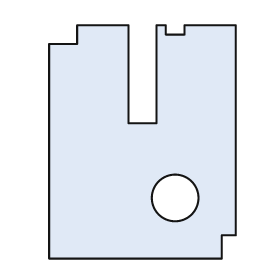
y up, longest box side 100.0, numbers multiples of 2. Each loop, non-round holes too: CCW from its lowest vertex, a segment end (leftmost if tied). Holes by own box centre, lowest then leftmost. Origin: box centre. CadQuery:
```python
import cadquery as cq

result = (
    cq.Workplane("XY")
    .moveTo(-40.0, -50.0)
    .lineTo(34.0, -50.0)
    .lineTo(34.0, -40.0)
    .lineTo(40.0, -40.0)
    .lineTo(40.0, 50.0)
    .lineTo(18.0, 50.0)
    .lineTo(18.0, 46.0)
    .lineTo(10.0, 46.0)
    .lineTo(10.0, 50.0)
    .lineTo(6.0, 50.0)
    .lineTo(6.0, 8.0)
    .lineTo(-6.0, 8.0)
    .lineTo(-6.0, 50.0)
    .lineTo(-28.0, 50.0)
    .lineTo(-28.0, 42.0)
    .lineTo(-40.0, 42.0)
    .close()
    .moveTo(14.0, -24.0)
    .circle(10.0)
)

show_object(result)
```